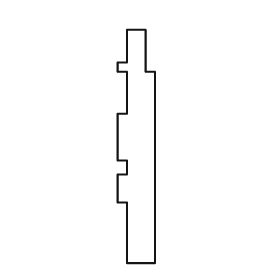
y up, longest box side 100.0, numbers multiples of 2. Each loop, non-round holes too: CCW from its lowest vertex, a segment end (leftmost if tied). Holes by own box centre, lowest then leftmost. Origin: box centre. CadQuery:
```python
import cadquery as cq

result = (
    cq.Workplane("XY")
    .moveTo(-4.0, -50.0)
    .lineTo(8.0, -50.0)
    .lineTo(8.0, 32.0)
    .lineTo(4.0, 32.0)
    .lineTo(4.0, 50.0)
    .lineTo(-4.0, 50.0)
    .lineTo(-4.0, 36.0)
    .lineTo(-8.0, 36.0)
    .lineTo(-8.0, 32.0)
    .lineTo(-4.0, 32.0)
    .lineTo(-4.0, 14.0)
    .lineTo(-8.0, 14.0)
    .lineTo(-8.0, -6.0)
    .lineTo(-4.0, -6.0)
    .lineTo(-4.0, -12.0)
    .lineTo(-8.0, -12.0)
    .lineTo(-8.0, -24.0)
    .lineTo(-4.0, -24.0)
    .close()
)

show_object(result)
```